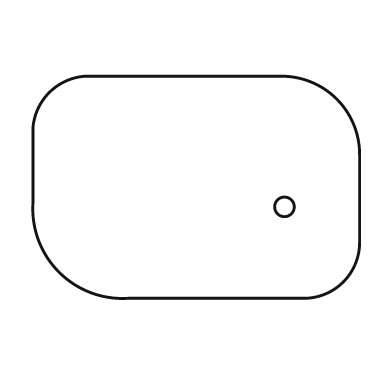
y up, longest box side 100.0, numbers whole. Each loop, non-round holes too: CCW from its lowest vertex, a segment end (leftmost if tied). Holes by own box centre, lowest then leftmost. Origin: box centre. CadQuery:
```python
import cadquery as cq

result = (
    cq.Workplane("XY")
    .moveTo(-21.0, -34.0)
    .lineTo(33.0, -34.0)
    .threePointArc((45.0, -29.0), (50.0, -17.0))
    .lineTo(50.0, 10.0)
    .threePointArc((43.0, 27.0), (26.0, 34.0))
    .lineTo(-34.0, 34.0)
    .threePointArc((-45.0, 29.0), (-50.0, 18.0))
    .lineTo(-50.0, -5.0)
    .threePointArc((-42.0, -26.0), (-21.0, -34.0))
    .close()
    .moveTo(27.0, -6.0)
    .circle(3.0)
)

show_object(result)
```